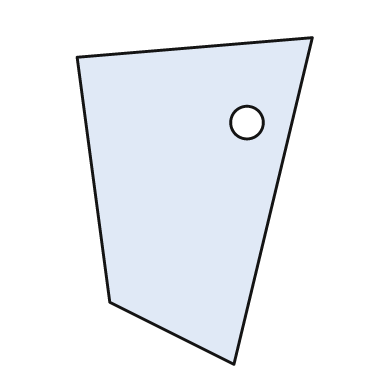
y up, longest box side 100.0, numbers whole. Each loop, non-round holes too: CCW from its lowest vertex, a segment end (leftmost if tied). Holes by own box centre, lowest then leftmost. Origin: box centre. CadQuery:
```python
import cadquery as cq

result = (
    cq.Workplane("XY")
    .moveTo(12.0, -50.0)
    .lineTo(36.0, 50.0)
    .lineTo(-36.0, 44.0)
    .lineTo(-26.0, -31.0)
    .close()
    .moveTo(16.0, 24.0)
    .circle(5.0)
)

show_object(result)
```